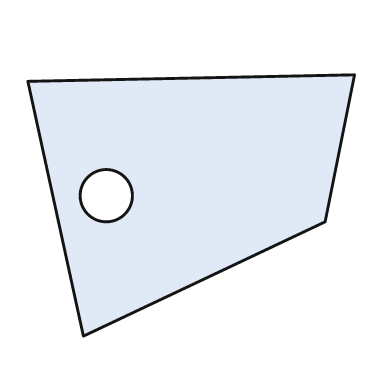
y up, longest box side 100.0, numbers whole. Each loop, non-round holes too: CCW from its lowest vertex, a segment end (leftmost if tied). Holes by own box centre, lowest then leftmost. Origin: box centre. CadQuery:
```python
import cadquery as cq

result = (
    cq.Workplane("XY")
    .moveTo(-33.0, -40.0)
    .lineTo(41.0, -5.0)
    .lineTo(50.0, 40.0)
    .lineTo(-50.0, 38.0)
    .close()
    .moveTo(-26.0, 3.0)
    .circle(8.0)
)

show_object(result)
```